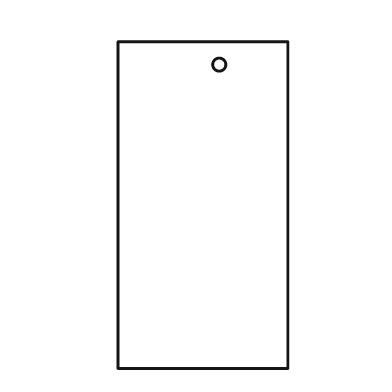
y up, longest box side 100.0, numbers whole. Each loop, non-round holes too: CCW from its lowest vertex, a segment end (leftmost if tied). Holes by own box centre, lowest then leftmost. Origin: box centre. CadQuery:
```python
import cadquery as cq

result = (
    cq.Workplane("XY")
    .moveTo(-26.0, -50.0)
    .lineTo(26.0, -50.0)
    .lineTo(26.0, 50.0)
    .lineTo(-26.0, 50.0)
    .close()
    .moveTo(5.0, 43.0)
    .circle(2.0)
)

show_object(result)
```